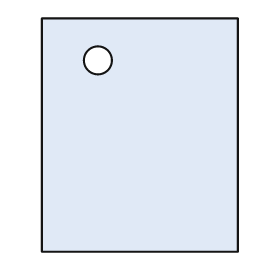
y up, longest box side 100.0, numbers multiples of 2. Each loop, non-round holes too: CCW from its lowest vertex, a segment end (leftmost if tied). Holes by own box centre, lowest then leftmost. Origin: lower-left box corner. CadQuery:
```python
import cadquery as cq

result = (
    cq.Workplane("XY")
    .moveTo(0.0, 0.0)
    .lineTo(84.0, 0.0)
    .lineTo(84.0, 100.0)
    .lineTo(0.0, 100.0)
    .close()
    .moveTo(24.0, 82.0)
    .circle(6.0)
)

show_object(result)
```